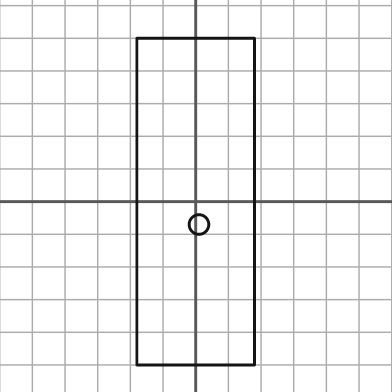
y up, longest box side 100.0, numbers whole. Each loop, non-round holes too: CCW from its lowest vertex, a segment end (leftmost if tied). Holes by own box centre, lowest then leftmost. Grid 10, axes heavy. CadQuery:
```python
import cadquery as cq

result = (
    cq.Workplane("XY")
    .moveTo(-18.0, -50.0)
    .lineTo(18.0, -50.0)
    .lineTo(18.0, 50.0)
    .lineTo(-18.0, 50.0)
    .close()
    .moveTo(1.0, -7.0)
    .circle(3.0)
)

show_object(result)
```